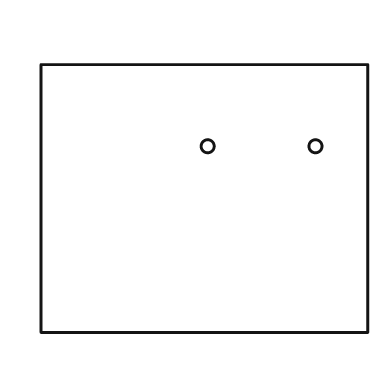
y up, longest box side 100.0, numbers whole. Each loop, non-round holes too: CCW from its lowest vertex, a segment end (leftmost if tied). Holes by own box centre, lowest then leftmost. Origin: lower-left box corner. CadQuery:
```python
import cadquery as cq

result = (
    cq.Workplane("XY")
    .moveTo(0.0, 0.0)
    .lineTo(100.0, 0.0)
    .lineTo(100.0, 82.0)
    .lineTo(0.0, 82.0)
    .close()
    .moveTo(51.0, 57.0)
    .circle(2.0)
    .moveTo(84.0, 57.0)
    .circle(2.0)
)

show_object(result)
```